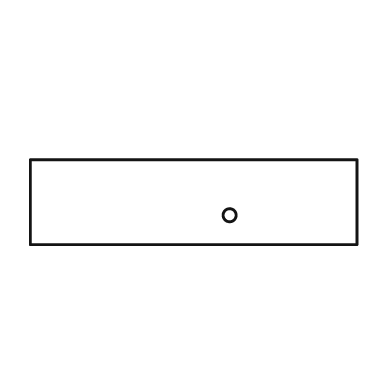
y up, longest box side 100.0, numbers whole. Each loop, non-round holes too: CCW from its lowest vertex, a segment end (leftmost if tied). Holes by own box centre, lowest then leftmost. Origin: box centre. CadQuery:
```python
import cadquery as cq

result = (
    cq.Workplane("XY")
    .moveTo(-50.0, -13.0)
    .lineTo(50.0, -13.0)
    .lineTo(50.0, 13.0)
    .lineTo(-50.0, 13.0)
    .close()
    .moveTo(11.0, -4.0)
    .circle(2.0)
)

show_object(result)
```